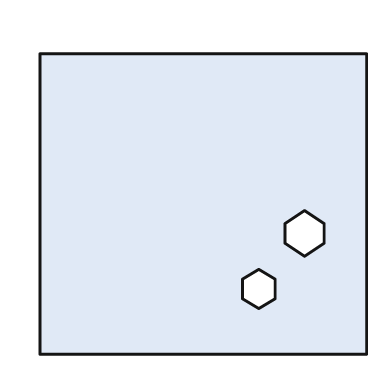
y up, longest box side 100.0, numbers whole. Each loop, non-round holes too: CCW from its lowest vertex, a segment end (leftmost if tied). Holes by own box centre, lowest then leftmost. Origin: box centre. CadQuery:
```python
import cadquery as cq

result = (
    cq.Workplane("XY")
    .moveTo(-50.0, -46.0)
    .lineTo(50.0, -46.0)
    .lineTo(50.0, 46.0)
    .lineTo(-50.0, 46.0)
    .close()
    .moveTo(17.0, -32.0)
    .lineTo(22.0, -29.0)
    .lineTo(22.0, -23.0)
    .lineTo(17.0, -20.0)
    .lineTo(12.0, -23.0)
    .lineTo(12.0, -29.0)
    .close()
    .moveTo(31.0, -16.0)
    .lineTo(37.0, -12.0)
    .lineTo(37.0, -6.0)
    .lineTo(31.0, -2.0)
    .lineTo(25.0, -6.0)
    .lineTo(25.0, -12.0)
    .close()
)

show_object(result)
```